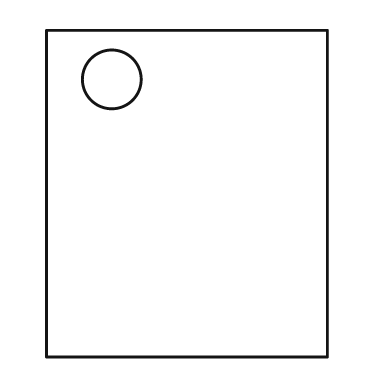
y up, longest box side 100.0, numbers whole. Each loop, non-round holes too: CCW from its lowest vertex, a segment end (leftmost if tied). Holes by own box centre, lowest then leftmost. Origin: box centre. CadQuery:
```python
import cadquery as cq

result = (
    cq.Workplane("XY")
    .moveTo(-43.0, -50.0)
    .lineTo(43.0, -50.0)
    .lineTo(43.0, 50.0)
    .lineTo(-43.0, 50.0)
    .close()
    .moveTo(-23.0, 35.0)
    .circle(9.0)
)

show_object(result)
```